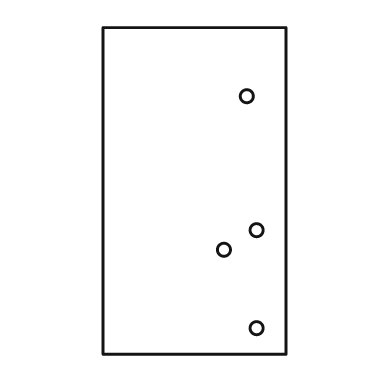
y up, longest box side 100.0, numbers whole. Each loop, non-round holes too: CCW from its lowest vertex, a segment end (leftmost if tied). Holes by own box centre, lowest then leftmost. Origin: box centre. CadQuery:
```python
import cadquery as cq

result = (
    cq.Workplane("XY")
    .moveTo(-28.0, -50.0)
    .lineTo(28.0, -50.0)
    .lineTo(28.0, 50.0)
    .lineTo(-28.0, 50.0)
    .close()
    .moveTo(19.0, -42.0)
    .circle(2.0)
    .moveTo(9.0, -18.0)
    .circle(2.0)
    .moveTo(19.0, -12.0)
    .circle(2.0)
    .moveTo(16.0, 29.0)
    .circle(2.0)
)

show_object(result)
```